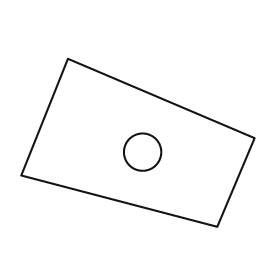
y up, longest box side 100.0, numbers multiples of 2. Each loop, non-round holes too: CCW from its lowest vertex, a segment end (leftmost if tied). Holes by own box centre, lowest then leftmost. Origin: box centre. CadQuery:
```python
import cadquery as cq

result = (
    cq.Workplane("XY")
    .moveTo(34.0, -36.0)
    .lineTo(50.0, 2.0)
    .lineTo(-30.0, 36.0)
    .lineTo(-50.0, -14.0)
    .close()
    .moveTo(2.0, -4.0)
    .circle(8.0)
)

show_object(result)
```